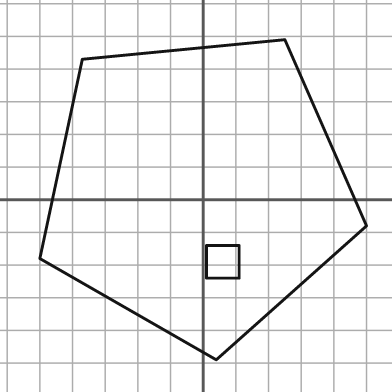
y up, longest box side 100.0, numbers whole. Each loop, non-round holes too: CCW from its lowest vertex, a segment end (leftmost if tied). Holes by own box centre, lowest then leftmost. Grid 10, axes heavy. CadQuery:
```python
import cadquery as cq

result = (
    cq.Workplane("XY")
    .moveTo(4.0, -49.0)
    .lineTo(50.0, -8.0)
    .lineTo(25.0, 49.0)
    .lineTo(-37.0, 43.0)
    .lineTo(-50.0, -18.0)
    .close()
    .moveTo(1.0, -24.0)
    .lineTo(11.0, -24.0)
    .lineTo(11.0, -14.0)
    .lineTo(1.0, -14.0)
    .close()
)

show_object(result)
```